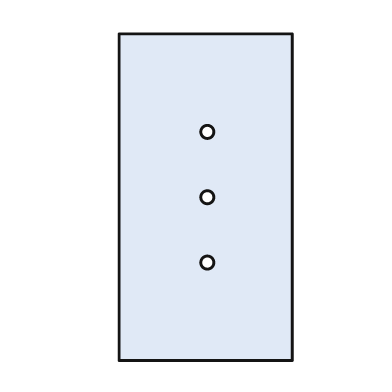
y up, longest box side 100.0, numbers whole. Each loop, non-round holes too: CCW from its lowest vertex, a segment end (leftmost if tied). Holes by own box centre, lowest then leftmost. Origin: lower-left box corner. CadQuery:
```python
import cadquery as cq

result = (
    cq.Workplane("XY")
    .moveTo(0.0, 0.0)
    .lineTo(53.0, 0.0)
    .lineTo(53.0, 100.0)
    .lineTo(0.0, 100.0)
    .close()
    .moveTo(27.0, 30.0)
    .circle(2.0)
    .moveTo(27.0, 50.0)
    .circle(2.0)
    .moveTo(27.0, 70.0)
    .circle(2.0)
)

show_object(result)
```